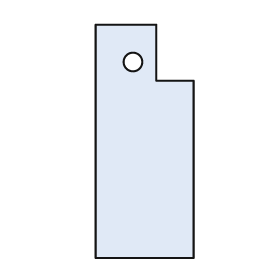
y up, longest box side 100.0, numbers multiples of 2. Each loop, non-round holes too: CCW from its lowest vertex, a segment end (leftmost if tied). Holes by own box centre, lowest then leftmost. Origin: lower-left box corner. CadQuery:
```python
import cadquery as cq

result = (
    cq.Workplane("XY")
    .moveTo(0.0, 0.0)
    .lineTo(42.0, 0.0)
    .lineTo(42.0, 76.0)
    .lineTo(26.0, 76.0)
    .lineTo(26.0, 100.0)
    .lineTo(0.0, 100.0)
    .close()
    .moveTo(16.0, 84.0)
    .circle(4.0)
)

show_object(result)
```